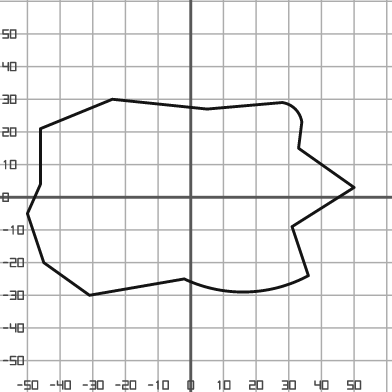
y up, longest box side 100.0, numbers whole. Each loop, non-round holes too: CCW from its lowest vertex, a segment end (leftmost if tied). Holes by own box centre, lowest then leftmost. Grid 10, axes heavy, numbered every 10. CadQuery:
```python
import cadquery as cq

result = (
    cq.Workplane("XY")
    .moveTo(-31.0, -30.0)
    .lineTo(-2.0, -25.0)
    .threePointArc((17.0, -29.0), (36.0, -24.0))
    .lineTo(31.0, -9.0)
    .lineTo(50.0, 3.0)
    .lineTo(33.0, 15.0)
    .lineTo(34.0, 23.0)
    .threePointArc((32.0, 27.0), (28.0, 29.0))
    .lineTo(5.0, 27.0)
    .lineTo(-24.0, 30.0)
    .lineTo(-46.0, 21.0)
    .lineTo(-46.0, 4.0)
    .lineTo(-50.0, -5.0)
    .lineTo(-45.0, -20.0)
    .close()
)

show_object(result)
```